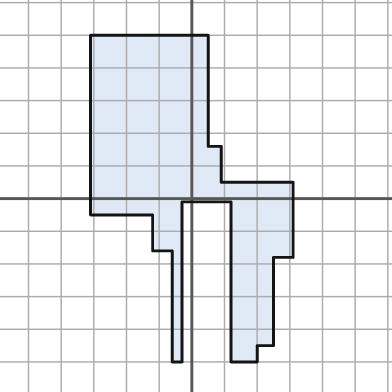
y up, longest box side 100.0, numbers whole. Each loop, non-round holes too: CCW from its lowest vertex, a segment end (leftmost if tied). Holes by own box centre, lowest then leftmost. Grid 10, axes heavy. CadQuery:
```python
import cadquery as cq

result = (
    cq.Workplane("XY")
    .moveTo(-6.0, -50.0)
    .lineTo(-3.0, -50.0)
    .lineTo(-3.0, -1.0)
    .lineTo(12.0, -1.0)
    .lineTo(12.0, -50.0)
    .lineTo(20.0, -50.0)
    .lineTo(20.0, -45.0)
    .lineTo(25.0, -45.0)
    .lineTo(25.0, -18.0)
    .lineTo(31.0, -18.0)
    .lineTo(31.0, 5.0)
    .lineTo(9.0, 5.0)
    .lineTo(9.0, 16.0)
    .lineTo(5.0, 16.0)
    .lineTo(5.0, 50.0)
    .lineTo(-31.0, 50.0)
    .lineTo(-31.0, -5.0)
    .lineTo(-12.0, -5.0)
    .lineTo(-12.0, -16.0)
    .lineTo(-6.0, -16.0)
    .close()
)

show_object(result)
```